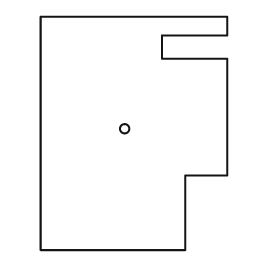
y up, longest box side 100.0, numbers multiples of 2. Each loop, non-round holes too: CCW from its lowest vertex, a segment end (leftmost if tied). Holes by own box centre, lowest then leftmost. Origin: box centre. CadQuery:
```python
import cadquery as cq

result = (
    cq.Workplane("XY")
    .moveTo(-40.0, -50.0)
    .lineTo(22.0, -50.0)
    .lineTo(22.0, -18.0)
    .lineTo(40.0, -18.0)
    .lineTo(40.0, 32.0)
    .lineTo(12.0, 32.0)
    .lineTo(12.0, 42.0)
    .lineTo(40.0, 42.0)
    .lineTo(40.0, 50.0)
    .lineTo(-40.0, 50.0)
    .close()
    .moveTo(-4.0, 2.0)
    .circle(2.0)
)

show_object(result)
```